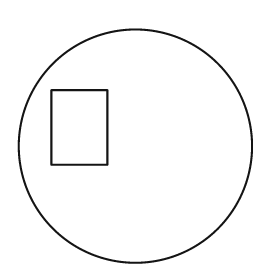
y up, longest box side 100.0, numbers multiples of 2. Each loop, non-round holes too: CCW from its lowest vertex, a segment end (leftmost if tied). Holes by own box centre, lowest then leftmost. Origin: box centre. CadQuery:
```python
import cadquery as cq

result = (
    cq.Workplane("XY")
    .moveTo(0.0, 0.0)
    .circle(50.0)
    .moveTo(-36.0, -8.0)
    .lineTo(-12.0, -8.0)
    .lineTo(-12.0, 24.0)
    .lineTo(-36.0, 24.0)
    .close()
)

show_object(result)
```